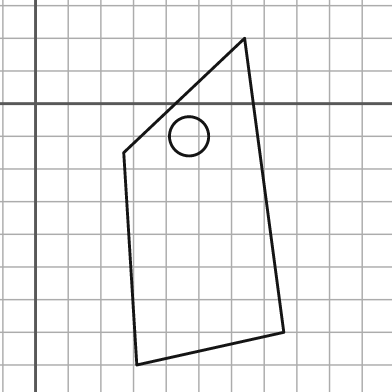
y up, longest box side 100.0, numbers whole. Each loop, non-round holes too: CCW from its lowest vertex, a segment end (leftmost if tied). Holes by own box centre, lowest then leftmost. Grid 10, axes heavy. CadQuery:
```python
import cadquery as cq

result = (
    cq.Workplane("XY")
    .moveTo(31.0, -80.0)
    .lineTo(76.0, -70.0)
    .lineTo(64.0, 20.0)
    .lineTo(27.0, -15.0)
    .close()
    .moveTo(47.0, -10.0)
    .circle(6.0)
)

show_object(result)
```